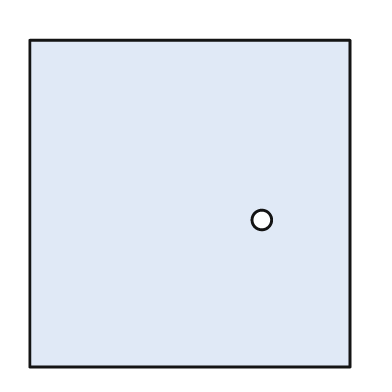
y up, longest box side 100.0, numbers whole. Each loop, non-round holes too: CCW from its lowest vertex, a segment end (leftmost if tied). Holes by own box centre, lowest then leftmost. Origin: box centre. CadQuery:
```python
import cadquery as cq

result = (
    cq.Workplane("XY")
    .moveTo(-49.0, -50.0)
    .lineTo(49.0, -50.0)
    .lineTo(49.0, 50.0)
    .lineTo(-49.0, 50.0)
    .close()
    .moveTo(22.0, -5.0)
    .circle(3.0)
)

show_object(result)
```